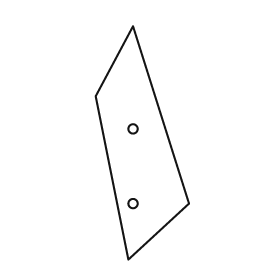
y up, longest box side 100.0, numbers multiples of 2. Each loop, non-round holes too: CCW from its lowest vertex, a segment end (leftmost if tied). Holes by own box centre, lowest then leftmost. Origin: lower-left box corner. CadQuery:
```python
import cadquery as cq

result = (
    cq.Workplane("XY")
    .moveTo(14.0, 0.0)
    .lineTo(40.0, 24.0)
    .lineTo(16.0, 100.0)
    .lineTo(0.0, 70.0)
    .close()
    .moveTo(16.0, 24.0)
    .circle(2.0)
    .moveTo(16.0, 56.0)
    .circle(2.0)
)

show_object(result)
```